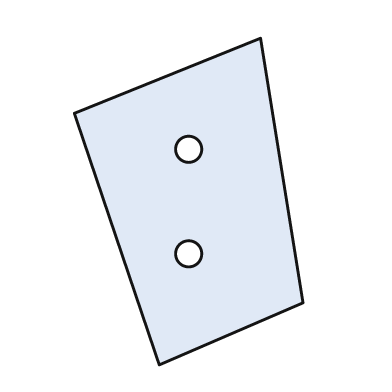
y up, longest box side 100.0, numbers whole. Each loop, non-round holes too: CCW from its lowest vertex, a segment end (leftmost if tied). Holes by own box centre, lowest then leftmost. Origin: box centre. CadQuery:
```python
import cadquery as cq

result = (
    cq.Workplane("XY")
    .moveTo(-9.0, -50.0)
    .lineTo(35.0, -31.0)
    .lineTo(22.0, 50.0)
    .lineTo(-35.0, 27.0)
    .close()
    .moveTo(0.0, -16.0)
    .circle(4.0)
    .moveTo(0.0, 16.0)
    .circle(4.0)
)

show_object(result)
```